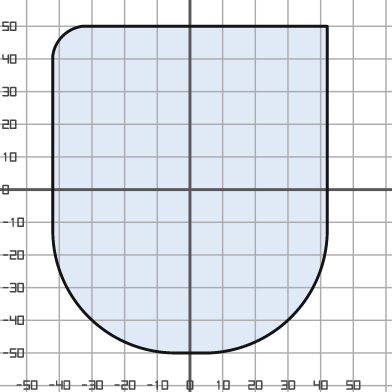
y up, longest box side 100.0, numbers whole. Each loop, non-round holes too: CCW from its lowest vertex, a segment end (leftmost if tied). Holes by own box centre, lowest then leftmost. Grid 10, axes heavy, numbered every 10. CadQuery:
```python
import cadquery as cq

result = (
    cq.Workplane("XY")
    .moveTo(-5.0, -50.0)
    .lineTo(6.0, -50.0)
    .threePointArc((31.0, -39.0), (42.0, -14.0))
    .lineTo(42.0, 50.0)
    .lineTo(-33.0, 50.0)
    .threePointArc((-39.0, 47.0), (-42.0, 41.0))
    .lineTo(-42.0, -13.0)
    .threePointArc((-31.0, -39.0), (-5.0, -50.0))
    .close()
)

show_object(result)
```